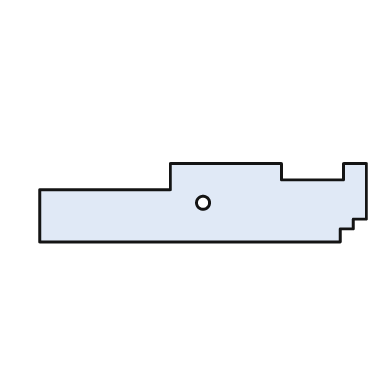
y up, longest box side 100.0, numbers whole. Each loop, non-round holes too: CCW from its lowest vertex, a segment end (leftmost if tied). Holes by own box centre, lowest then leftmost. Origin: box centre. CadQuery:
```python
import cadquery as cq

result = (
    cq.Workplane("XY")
    .moveTo(-50.0, -12.0)
    .lineTo(42.0, -12.0)
    .lineTo(42.0, -8.0)
    .lineTo(46.0, -8.0)
    .lineTo(46.0, -5.0)
    .lineTo(50.0, -5.0)
    .lineTo(50.0, 12.0)
    .lineTo(43.0, 12.0)
    .lineTo(43.0, 7.0)
    .lineTo(24.0, 7.0)
    .lineTo(24.0, 12.0)
    .lineTo(-10.0, 12.0)
    .lineTo(-10.0, 4.0)
    .lineTo(-50.0, 4.0)
    .close()
    .moveTo(0.0, 0.0)
    .circle(2.0)
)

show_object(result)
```